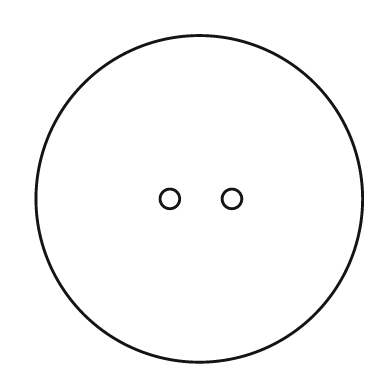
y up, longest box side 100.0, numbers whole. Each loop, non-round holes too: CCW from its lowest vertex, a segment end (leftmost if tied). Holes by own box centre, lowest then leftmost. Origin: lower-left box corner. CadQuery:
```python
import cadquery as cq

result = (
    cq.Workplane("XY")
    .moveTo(50.0, 50.0)
    .circle(50.0)
    .moveTo(41.0, 50.0)
    .circle(3.0)
    .moveTo(60.0, 50.0)
    .circle(3.0)
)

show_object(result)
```